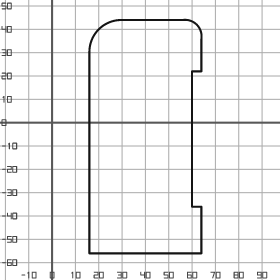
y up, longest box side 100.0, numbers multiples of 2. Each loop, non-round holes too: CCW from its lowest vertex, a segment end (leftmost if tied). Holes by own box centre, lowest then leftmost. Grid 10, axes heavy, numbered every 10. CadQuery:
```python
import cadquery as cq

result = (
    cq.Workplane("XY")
    .moveTo(16.0, -56.0)
    .lineTo(64.0, -56.0)
    .lineTo(64.0, -36.0)
    .lineTo(60.0, -36.0)
    .lineTo(60.0, 22.0)
    .lineTo(64.0, 22.0)
    .lineTo(64.0, 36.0)
    .threePointArc((62.0, 42.0), (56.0, 44.0))
    .lineTo(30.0, 44.0)
    .threePointArc((20.0, 40.0), (16.0, 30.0))
    .close()
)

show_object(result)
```